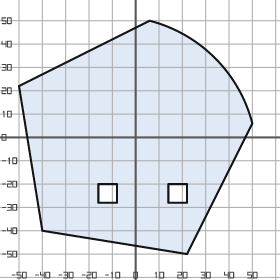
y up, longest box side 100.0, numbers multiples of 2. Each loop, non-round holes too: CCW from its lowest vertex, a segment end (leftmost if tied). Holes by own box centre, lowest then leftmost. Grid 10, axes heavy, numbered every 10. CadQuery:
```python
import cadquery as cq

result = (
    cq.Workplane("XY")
    .moveTo(22.0, -50.0)
    .lineTo(50.0, 6.0)
    .threePointArc((34.0, 34.0), (6.0, 50.0))
    .lineTo(-50.0, 22.0)
    .lineTo(-40.0, -40.0)
    .close()
    .moveTo(-16.0, -28.0)
    .lineTo(-8.0, -28.0)
    .lineTo(-8.0, -20.0)
    .lineTo(-16.0, -20.0)
    .close()
    .moveTo(14.0, -28.0)
    .lineTo(22.0, -28.0)
    .lineTo(22.0, -20.0)
    .lineTo(14.0, -20.0)
    .close()
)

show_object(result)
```